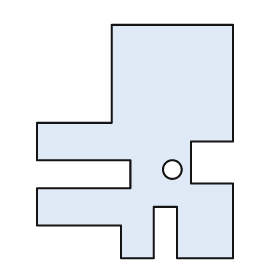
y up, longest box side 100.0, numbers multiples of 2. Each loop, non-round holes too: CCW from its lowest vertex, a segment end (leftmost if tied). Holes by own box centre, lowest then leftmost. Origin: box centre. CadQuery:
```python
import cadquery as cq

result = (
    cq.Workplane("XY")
    .moveTo(-6.0, -50.0)
    .lineTo(8.0, -50.0)
    .lineTo(8.0, -28.0)
    .lineTo(18.0, -28.0)
    .lineTo(18.0, -50.0)
    .lineTo(42.0, -50.0)
    .lineTo(42.0, -18.0)
    .lineTo(24.0, -18.0)
    .lineTo(24.0, 0.0)
    .lineTo(42.0, 0.0)
    .lineTo(42.0, 50.0)
    .lineTo(-10.0, 50.0)
    .lineTo(-10.0, 8.0)
    .lineTo(-42.0, 8.0)
    .lineTo(-42.0, -8.0)
    .lineTo(-2.0, -8.0)
    .lineTo(-2.0, -20.0)
    .lineTo(-42.0, -20.0)
    .lineTo(-42.0, -36.0)
    .lineTo(-6.0, -36.0)
    .close()
    .moveTo(16.0, -12.0)
    .circle(4.0)
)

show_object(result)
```